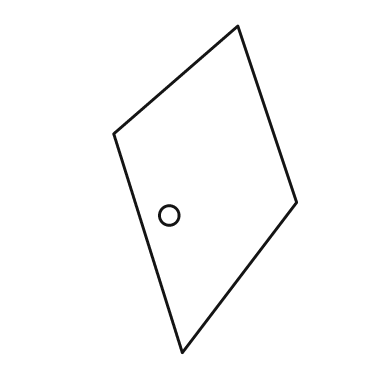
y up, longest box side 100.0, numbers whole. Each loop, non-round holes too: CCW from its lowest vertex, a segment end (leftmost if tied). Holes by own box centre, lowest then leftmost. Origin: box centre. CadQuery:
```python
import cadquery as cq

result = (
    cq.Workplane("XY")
    .moveTo(-7.0, -50.0)
    .lineTo(28.0, -4.0)
    .lineTo(10.0, 50.0)
    .lineTo(-28.0, 17.0)
    .close()
    .moveTo(-11.0, -8.0)
    .circle(3.0)
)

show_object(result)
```